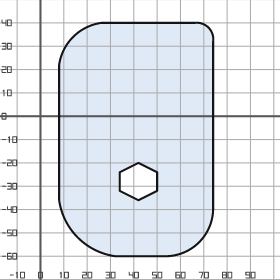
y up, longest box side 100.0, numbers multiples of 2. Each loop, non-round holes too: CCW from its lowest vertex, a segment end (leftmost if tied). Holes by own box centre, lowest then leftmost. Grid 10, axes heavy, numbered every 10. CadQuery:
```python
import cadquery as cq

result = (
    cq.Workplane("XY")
    .moveTo(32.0, -60.0)
    .lineTo(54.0, -60.0)
    .threePointArc((68.0, -54.0), (74.0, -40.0))
    .lineTo(74.0, 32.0)
    .threePointArc((72.0, 38.0), (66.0, 40.0))
    .lineTo(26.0, 40.0)
    .threePointArc((14.0, 34.0), (8.0, 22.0))
    .lineTo(8.0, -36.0)
    .threePointArc((16.0, -52.0), (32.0, -60.0))
    .close()
    .moveTo(42.0, -36.0)
    .lineTo(50.0, -32.0)
    .lineTo(50.0, -24.0)
    .lineTo(42.0, -20.0)
    .lineTo(34.0, -24.0)
    .lineTo(34.0, -32.0)
    .close()
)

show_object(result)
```